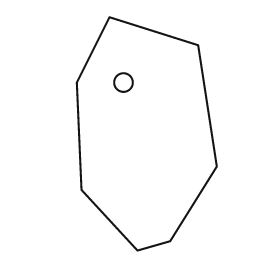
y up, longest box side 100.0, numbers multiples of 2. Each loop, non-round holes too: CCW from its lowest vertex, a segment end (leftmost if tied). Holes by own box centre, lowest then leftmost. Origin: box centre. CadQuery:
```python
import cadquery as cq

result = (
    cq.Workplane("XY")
    .moveTo(-4.0, -50.0)
    .lineTo(10.0, -46.0)
    .lineTo(30.0, -14.0)
    .lineTo(22.0, 38.0)
    .lineTo(-16.0, 50.0)
    .lineTo(-30.0, 22.0)
    .lineTo(-28.0, -24.0)
    .close()
    .moveTo(-10.0, 22.0)
    .circle(4.0)
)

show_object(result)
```